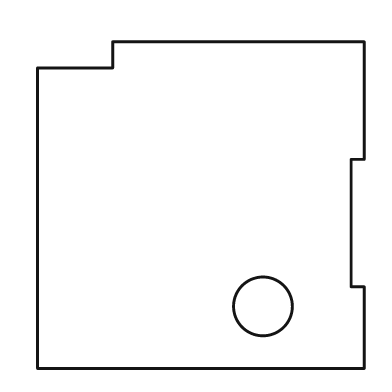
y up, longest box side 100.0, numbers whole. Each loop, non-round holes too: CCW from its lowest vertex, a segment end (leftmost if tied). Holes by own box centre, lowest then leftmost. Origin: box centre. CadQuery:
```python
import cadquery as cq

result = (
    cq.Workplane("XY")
    .moveTo(-50.0, -50.0)
    .lineTo(50.0, -50.0)
    .lineTo(50.0, -25.0)
    .lineTo(46.0, -25.0)
    .lineTo(46.0, 14.0)
    .lineTo(50.0, 14.0)
    .lineTo(50.0, 50.0)
    .lineTo(-27.0, 50.0)
    .lineTo(-27.0, 42.0)
    .lineTo(-50.0, 42.0)
    .close()
    .moveTo(19.0, -31.0)
    .circle(9.0)
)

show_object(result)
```